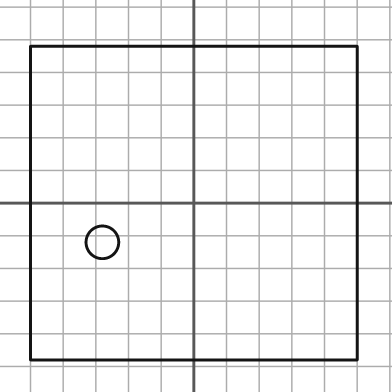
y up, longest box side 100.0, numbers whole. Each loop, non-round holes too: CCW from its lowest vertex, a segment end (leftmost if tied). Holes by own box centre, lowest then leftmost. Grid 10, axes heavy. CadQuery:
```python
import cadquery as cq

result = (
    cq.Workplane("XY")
    .moveTo(-50.0, -48.0)
    .lineTo(50.0, -48.0)
    .lineTo(50.0, 48.0)
    .lineTo(-50.0, 48.0)
    .close()
    .moveTo(-28.0, -12.0)
    .circle(5.0)
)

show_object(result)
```